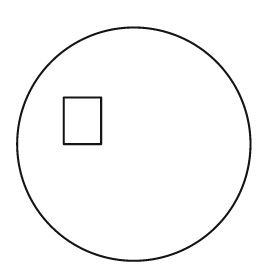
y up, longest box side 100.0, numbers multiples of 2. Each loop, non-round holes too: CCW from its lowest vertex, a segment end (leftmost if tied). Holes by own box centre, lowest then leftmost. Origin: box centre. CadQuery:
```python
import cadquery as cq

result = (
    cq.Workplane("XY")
    .moveTo(0.0, 0.0)
    .circle(50.0)
    .moveTo(-30.0, 0.0)
    .lineTo(-14.0, 0.0)
    .lineTo(-14.0, 20.0)
    .lineTo(-30.0, 20.0)
    .close()
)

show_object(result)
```